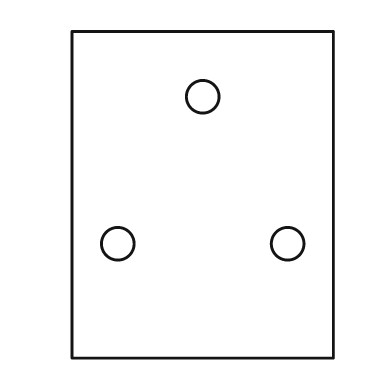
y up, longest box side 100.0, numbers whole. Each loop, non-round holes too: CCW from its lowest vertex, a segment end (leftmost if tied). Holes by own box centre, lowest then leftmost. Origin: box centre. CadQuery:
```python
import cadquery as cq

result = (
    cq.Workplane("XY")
    .moveTo(-40.0, -50.0)
    .lineTo(40.0, -50.0)
    .lineTo(40.0, 50.0)
    .lineTo(-40.0, 50.0)
    .close()
    .moveTo(-26.0, -15.0)
    .circle(5.0)
    .moveTo(26.0, -15.0)
    .circle(5.0)
    .moveTo(0.0, 30.0)
    .circle(5.0)
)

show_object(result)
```